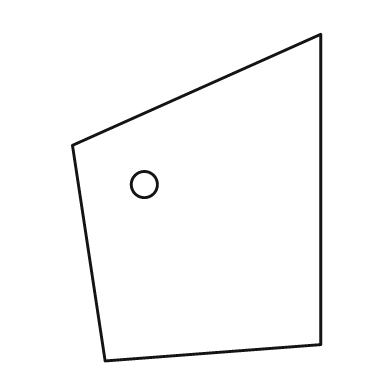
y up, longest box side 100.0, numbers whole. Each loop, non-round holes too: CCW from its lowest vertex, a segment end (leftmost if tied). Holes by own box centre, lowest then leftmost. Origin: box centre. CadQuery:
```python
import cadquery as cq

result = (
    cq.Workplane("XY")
    .moveTo(-28.0, -50.0)
    .lineTo(38.0, -45.0)
    .lineTo(38.0, 50.0)
    .lineTo(-38.0, 16.0)
    .close()
    .moveTo(-16.0, 4.0)
    .circle(4.0)
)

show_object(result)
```